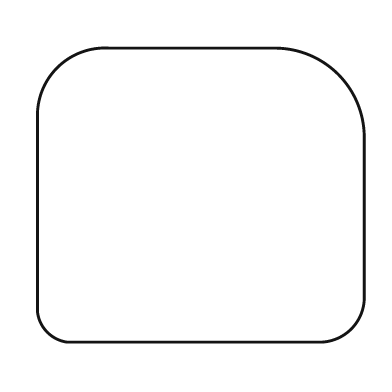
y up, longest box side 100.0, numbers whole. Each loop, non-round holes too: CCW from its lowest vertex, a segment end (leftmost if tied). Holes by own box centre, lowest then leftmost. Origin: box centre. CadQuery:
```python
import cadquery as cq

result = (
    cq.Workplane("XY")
    .moveTo(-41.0, -45.0)
    .lineTo(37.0, -45.0)
    .threePointArc((46.0, -41.0), (50.0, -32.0))
    .lineTo(50.0, 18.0)
    .threePointArc((42.0, 37.0), (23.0, 45.0))
    .lineTo(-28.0, 45.0)
    .threePointArc((-44.0, 39.0), (-50.0, 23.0))
    .lineTo(-50.0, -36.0)
    .threePointArc((-47.0, -42.0), (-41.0, -45.0))
    .close()
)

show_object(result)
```